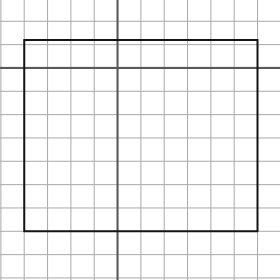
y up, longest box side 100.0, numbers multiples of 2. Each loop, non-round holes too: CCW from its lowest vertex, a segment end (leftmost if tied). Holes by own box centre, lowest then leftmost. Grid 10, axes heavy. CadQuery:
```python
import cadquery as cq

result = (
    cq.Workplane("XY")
    .moveTo(-40.0, -70.0)
    .lineTo(60.0, -70.0)
    .lineTo(60.0, 12.0)
    .lineTo(-40.0, 12.0)
    .close()
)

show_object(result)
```